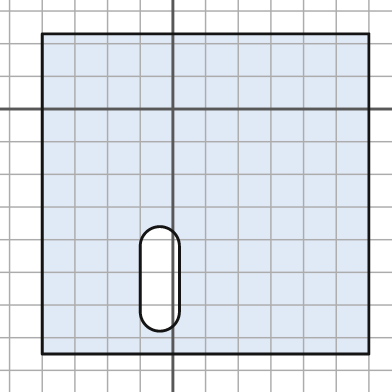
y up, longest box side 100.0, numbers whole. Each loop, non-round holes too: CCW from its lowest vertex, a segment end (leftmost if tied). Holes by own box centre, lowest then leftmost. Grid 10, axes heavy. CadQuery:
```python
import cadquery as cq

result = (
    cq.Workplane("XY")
    .moveTo(-40.0, -75.0)
    .lineTo(60.0, -75.0)
    .lineTo(60.0, 23.0)
    .lineTo(-40.0, 23.0)
    .close()
    .moveTo(-10.0, -62.0)
    .threePointArc((-4.0, -68.0), (2.0, -62.0))
    .lineTo(2.0, -42.0)
    .threePointArc((-4.0, -36.0), (-10.0, -42.0))
    .close()
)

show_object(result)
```